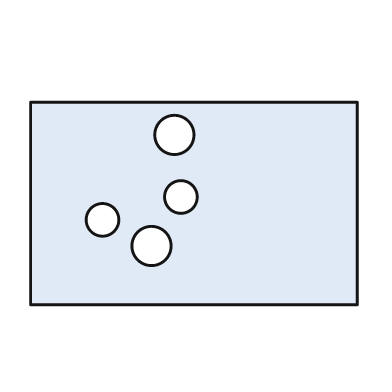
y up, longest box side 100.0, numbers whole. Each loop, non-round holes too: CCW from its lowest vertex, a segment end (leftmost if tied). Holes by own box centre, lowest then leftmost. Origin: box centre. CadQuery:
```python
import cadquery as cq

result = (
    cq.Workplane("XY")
    .moveTo(-50.0, -31.0)
    .lineTo(50.0, -31.0)
    .lineTo(50.0, 31.0)
    .lineTo(-50.0, 31.0)
    .close()
    .moveTo(-13.0, -13.0)
    .circle(6.0)
    .moveTo(-28.0, -5.0)
    .circle(5.0)
    .moveTo(-4.0, 2.0)
    .circle(5.0)
    .moveTo(-6.0, 21.0)
    .circle(6.0)
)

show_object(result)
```